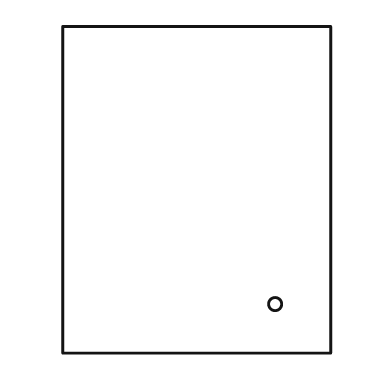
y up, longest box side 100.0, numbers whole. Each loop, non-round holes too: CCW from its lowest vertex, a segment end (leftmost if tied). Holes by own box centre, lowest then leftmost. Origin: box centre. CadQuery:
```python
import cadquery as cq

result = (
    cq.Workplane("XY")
    .moveTo(-41.0, -50.0)
    .lineTo(41.0, -50.0)
    .lineTo(41.0, 50.0)
    .lineTo(-41.0, 50.0)
    .close()
    .moveTo(24.0, -35.0)
    .circle(2.0)
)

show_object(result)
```